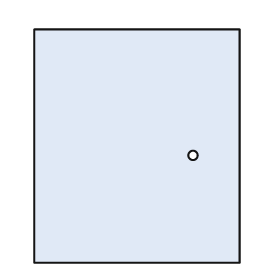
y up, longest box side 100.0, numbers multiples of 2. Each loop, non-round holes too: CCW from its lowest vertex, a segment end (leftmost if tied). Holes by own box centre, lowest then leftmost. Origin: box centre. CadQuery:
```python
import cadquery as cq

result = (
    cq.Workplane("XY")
    .moveTo(-44.0, -50.0)
    .lineTo(44.0, -50.0)
    .lineTo(44.0, 50.0)
    .lineTo(-44.0, 50.0)
    .close()
    .moveTo(24.0, -4.0)
    .circle(2.0)
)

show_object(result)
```